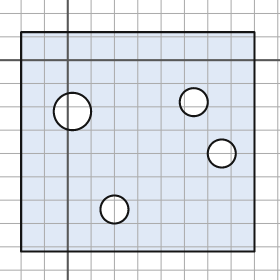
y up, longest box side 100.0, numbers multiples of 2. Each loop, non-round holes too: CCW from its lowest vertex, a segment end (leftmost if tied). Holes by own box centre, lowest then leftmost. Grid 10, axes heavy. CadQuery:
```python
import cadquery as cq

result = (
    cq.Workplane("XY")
    .moveTo(-20.0, -82.0)
    .lineTo(80.0, -82.0)
    .lineTo(80.0, 12.0)
    .lineTo(-20.0, 12.0)
    .close()
    .moveTo(20.0, -64.0)
    .circle(6.0)
    .moveTo(66.0, -40.0)
    .circle(6.0)
    .moveTo(2.0, -22.0)
    .circle(8.0)
    .moveTo(54.0, -18.0)
    .circle(6.0)
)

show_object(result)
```